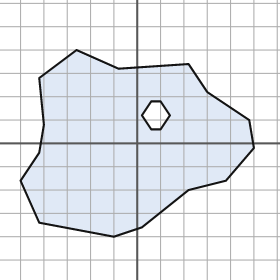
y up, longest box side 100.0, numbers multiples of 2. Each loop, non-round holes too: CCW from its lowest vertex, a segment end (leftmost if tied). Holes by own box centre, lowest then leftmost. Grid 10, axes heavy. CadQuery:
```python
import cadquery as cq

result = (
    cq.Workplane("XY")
    .moveTo(-10.0, -40.0)
    .lineTo(2.0, -36.0)
    .lineTo(22.0, -20.0)
    .lineTo(38.0, -16.0)
    .lineTo(50.0, -2.0)
    .lineTo(48.0, 10.0)
    .lineTo(30.0, 22.0)
    .lineTo(22.0, 34.0)
    .lineTo(-8.0, 32.0)
    .lineTo(-26.0, 40.0)
    .lineTo(-42.0, 28.0)
    .lineTo(-40.0, 8.0)
    .lineTo(-42.0, -4.0)
    .lineTo(-50.0, -16.0)
    .lineTo(-42.0, -34.0)
    .close()
    .moveTo(6.0, 6.0)
    .lineTo(10.0, 6.0)
    .lineTo(14.0, 12.0)
    .lineTo(10.0, 18.0)
    .lineTo(6.0, 18.0)
    .lineTo(2.0, 12.0)
    .close()
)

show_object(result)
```